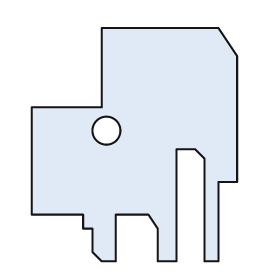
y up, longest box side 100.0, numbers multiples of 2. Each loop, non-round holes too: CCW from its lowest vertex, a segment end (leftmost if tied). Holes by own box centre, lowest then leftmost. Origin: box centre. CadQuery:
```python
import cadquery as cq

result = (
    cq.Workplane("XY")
    .moveTo(-14.0, -50.0)
    .lineTo(-8.0, -50.0)
    .lineTo(-8.0, -30.0)
    .lineTo(6.0, -30.0)
    .lineTo(10.0, -36.0)
    .lineTo(10.0, -50.0)
    .lineTo(18.0, -50.0)
    .lineTo(18.0, -2.0)
    .lineTo(26.0, -2.0)
    .lineTo(30.0, -6.0)
    .lineTo(30.0, -50.0)
    .lineTo(36.0, -50.0)
    .lineTo(36.0, -16.0)
    .lineTo(44.0, -16.0)
    .lineTo(44.0, 38.0)
    .lineTo(36.0, 50.0)
    .lineTo(-14.0, 50.0)
    .lineTo(-14.0, 16.0)
    .lineTo(-44.0, 16.0)
    .lineTo(-44.0, -30.0)
    .lineTo(-22.0, -30.0)
    .lineTo(-22.0, -36.0)
    .lineTo(-18.0, -36.0)
    .lineTo(-18.0, -46.0)
    .close()
    .moveTo(-12.0, 6.0)
    .circle(6.0)
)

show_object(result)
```